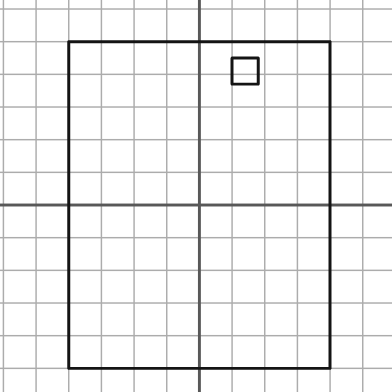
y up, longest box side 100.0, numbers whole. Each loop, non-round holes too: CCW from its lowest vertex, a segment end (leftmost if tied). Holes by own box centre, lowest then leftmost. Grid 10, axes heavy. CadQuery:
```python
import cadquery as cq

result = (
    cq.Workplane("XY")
    .moveTo(-40.0, -50.0)
    .lineTo(40.0, -50.0)
    .lineTo(40.0, 50.0)
    .lineTo(-40.0, 50.0)
    .close()
    .moveTo(10.0, 37.0)
    .lineTo(18.0, 37.0)
    .lineTo(18.0, 45.0)
    .lineTo(10.0, 45.0)
    .close()
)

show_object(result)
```